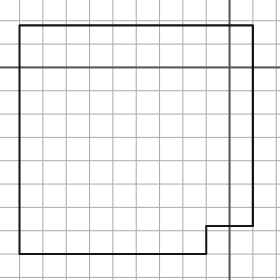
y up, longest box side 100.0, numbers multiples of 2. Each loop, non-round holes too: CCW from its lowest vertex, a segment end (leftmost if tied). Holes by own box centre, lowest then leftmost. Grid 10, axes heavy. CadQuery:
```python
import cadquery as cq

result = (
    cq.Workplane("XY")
    .moveTo(-90.0, -80.0)
    .lineTo(-10.0, -80.0)
    .lineTo(-10.0, -68.0)
    .lineTo(10.0, -68.0)
    .lineTo(10.0, 18.0)
    .lineTo(-90.0, 18.0)
    .close()
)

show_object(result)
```